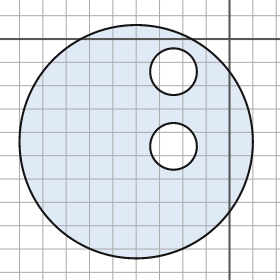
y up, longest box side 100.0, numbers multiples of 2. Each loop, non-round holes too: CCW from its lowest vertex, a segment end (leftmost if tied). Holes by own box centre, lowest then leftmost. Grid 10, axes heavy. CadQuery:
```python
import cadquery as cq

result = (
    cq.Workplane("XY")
    .moveTo(-40.0, -44.0)
    .circle(50.0)
    .moveTo(-24.0, -46.0)
    .circle(10.0)
    .moveTo(-24.0, -14.0)
    .circle(10.0)
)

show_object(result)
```